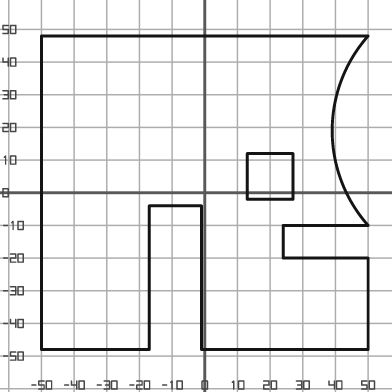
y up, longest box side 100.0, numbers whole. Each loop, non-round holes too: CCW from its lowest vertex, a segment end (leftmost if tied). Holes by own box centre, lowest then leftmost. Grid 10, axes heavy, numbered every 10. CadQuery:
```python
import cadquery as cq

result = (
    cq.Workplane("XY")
    .moveTo(-50.0, -48.0)
    .lineTo(-17.0, -48.0)
    .lineTo(-17.0, -4.0)
    .lineTo(-1.0, -4.0)
    .lineTo(-1.0, -48.0)
    .lineTo(50.0, -48.0)
    .lineTo(50.0, -20.0)
    .lineTo(24.0, -20.0)
    .lineTo(24.0, -10.0)
    .lineTo(50.0, -10.0)
    .threePointArc((39.0, 19.0), (50.0, 48.0))
    .lineTo(-50.0, 48.0)
    .close()
    .moveTo(13.0, -2.0)
    .lineTo(27.0, -2.0)
    .lineTo(27.0, 12.0)
    .lineTo(13.0, 12.0)
    .close()
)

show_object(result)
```